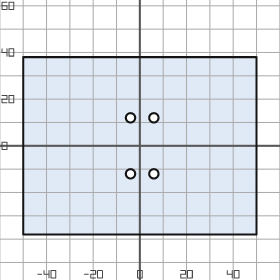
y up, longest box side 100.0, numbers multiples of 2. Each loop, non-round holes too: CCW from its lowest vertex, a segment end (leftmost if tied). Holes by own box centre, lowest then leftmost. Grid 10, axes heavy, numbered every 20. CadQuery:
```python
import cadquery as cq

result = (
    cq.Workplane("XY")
    .moveTo(-50.0, -38.0)
    .lineTo(50.0, -38.0)
    .lineTo(50.0, 38.0)
    .lineTo(-50.0, 38.0)
    .close()
    .moveTo(-4.0, -12.0)
    .circle(2.0)
    .moveTo(6.0, -12.0)
    .circle(2.0)
    .moveTo(-4.0, 12.0)
    .circle(2.0)
    .moveTo(6.0, 12.0)
    .circle(2.0)
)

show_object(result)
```